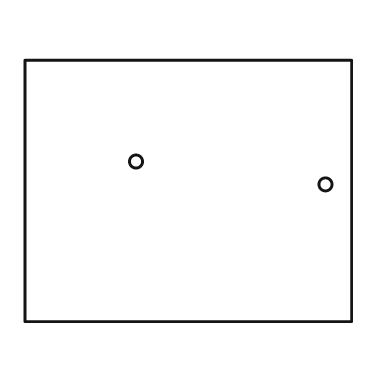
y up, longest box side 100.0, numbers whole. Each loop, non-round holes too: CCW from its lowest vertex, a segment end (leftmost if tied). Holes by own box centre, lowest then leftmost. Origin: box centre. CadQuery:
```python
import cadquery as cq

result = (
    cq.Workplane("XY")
    .moveTo(-50.0, -40.0)
    .lineTo(50.0, -40.0)
    .lineTo(50.0, 40.0)
    .lineTo(-50.0, 40.0)
    .close()
    .moveTo(42.0, 2.0)
    .circle(2.0)
    .moveTo(-16.0, 9.0)
    .circle(2.0)
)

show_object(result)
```